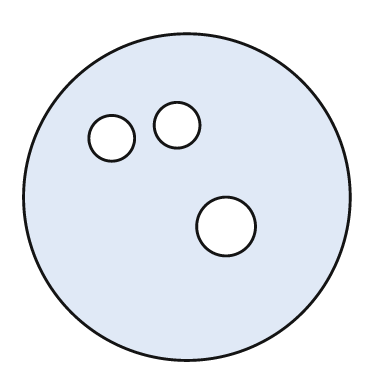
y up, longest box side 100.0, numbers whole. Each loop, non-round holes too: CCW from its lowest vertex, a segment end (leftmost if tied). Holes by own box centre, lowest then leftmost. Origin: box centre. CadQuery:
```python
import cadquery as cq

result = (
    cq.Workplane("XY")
    .moveTo(0.0, 0.0)
    .circle(50.0)
    .moveTo(12.0, -9.0)
    .circle(9.0)
    .moveTo(-23.0, 18.0)
    .circle(7.0)
    .moveTo(-3.0, 22.0)
    .circle(7.0)
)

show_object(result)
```